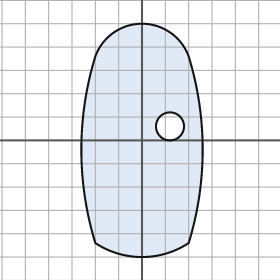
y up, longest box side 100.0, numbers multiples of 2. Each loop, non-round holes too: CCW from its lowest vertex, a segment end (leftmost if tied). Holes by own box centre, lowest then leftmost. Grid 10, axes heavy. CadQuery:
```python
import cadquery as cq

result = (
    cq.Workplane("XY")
    .moveTo(-20.0, -44.0)
    .threePointArc((0.0, -50.0), (20.0, -44.0))
    .threePointArc((26.0, -4.0), (20.0, 36.0))
    .threePointArc((0.0, 50.0), (-20.0, 36.0))
    .threePointArc((-26.0, -4.0), (-20.0, -44.0))
    .close()
    .moveTo(12.0, 6.0)
    .circle(6.0)
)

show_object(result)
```